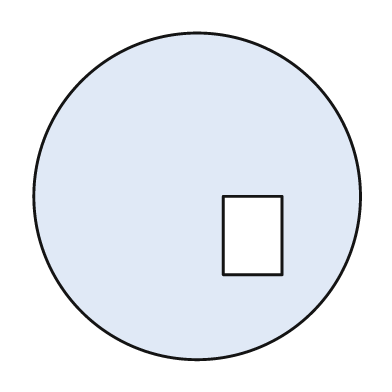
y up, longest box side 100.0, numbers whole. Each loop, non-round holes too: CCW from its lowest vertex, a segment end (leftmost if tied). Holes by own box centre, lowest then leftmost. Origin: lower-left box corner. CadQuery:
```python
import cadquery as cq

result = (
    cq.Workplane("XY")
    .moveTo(50.0, 50.0)
    .circle(50.0)
    .moveTo(58.0, 26.0)
    .lineTo(76.0, 26.0)
    .lineTo(76.0, 50.0)
    .lineTo(58.0, 50.0)
    .close()
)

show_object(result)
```